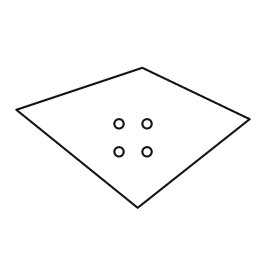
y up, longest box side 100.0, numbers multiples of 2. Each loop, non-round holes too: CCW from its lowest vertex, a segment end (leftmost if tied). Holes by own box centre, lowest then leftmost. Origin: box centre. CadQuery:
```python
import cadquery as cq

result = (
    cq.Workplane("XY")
    .moveTo(2.0, -30.0)
    .lineTo(50.0, 8.0)
    .lineTo(4.0, 30.0)
    .lineTo(-50.0, 12.0)
    .close()
    .moveTo(-6.0, -6.0)
    .circle(2.0)
    .moveTo(6.0, -6.0)
    .circle(2.0)
    .moveTo(-6.0, 6.0)
    .circle(2.0)
    .moveTo(6.0, 6.0)
    .circle(2.0)
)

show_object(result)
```